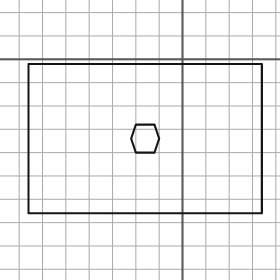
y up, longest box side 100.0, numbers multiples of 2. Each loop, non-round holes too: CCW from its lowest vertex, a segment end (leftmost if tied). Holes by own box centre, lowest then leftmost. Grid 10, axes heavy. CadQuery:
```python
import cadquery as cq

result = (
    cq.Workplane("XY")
    .moveTo(-66.0, -66.0)
    .lineTo(34.0, -66.0)
    .lineTo(34.0, -2.0)
    .lineTo(-66.0, -2.0)
    .close()
    .moveTo(-20.0, -40.0)
    .lineTo(-12.0, -40.0)
    .lineTo(-10.0, -34.0)
    .lineTo(-12.0, -28.0)
    .lineTo(-20.0, -28.0)
    .lineTo(-22.0, -34.0)
    .close()
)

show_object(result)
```